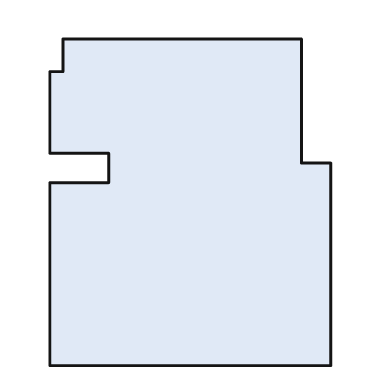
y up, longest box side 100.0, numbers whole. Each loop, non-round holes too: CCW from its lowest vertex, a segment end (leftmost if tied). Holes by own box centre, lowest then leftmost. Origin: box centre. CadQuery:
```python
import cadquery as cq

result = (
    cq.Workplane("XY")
    .moveTo(-43.0, -50.0)
    .lineTo(43.0, -50.0)
    .lineTo(43.0, 12.0)
    .lineTo(34.0, 12.0)
    .lineTo(34.0, 50.0)
    .lineTo(-39.0, 50.0)
    .lineTo(-39.0, 40.0)
    .lineTo(-43.0, 40.0)
    .lineTo(-43.0, 15.0)
    .lineTo(-25.0, 15.0)
    .lineTo(-25.0, 6.0)
    .lineTo(-43.0, 6.0)
    .close()
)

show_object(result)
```